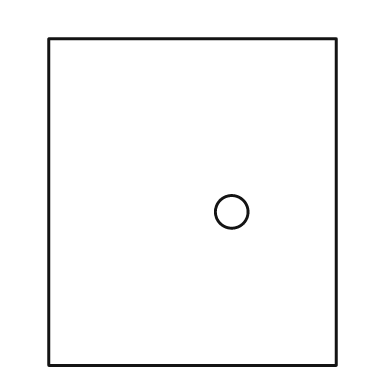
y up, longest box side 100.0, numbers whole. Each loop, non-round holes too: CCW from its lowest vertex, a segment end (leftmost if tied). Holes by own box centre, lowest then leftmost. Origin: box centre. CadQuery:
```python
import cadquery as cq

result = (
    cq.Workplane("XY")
    .moveTo(-44.0, -50.0)
    .lineTo(44.0, -50.0)
    .lineTo(44.0, 50.0)
    .lineTo(-44.0, 50.0)
    .close()
    .moveTo(12.0, -3.0)
    .circle(5.0)
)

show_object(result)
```